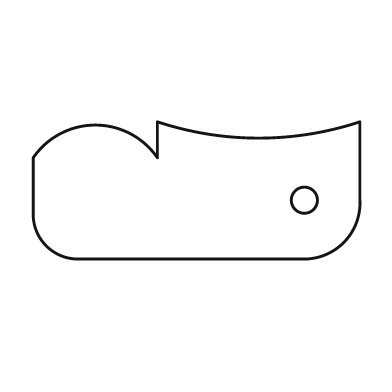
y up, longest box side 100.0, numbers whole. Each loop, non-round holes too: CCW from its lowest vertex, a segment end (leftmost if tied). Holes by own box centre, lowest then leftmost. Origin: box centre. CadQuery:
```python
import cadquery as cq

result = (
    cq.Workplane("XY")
    .moveTo(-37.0, -21.0)
    .lineTo(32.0, -21.0)
    .threePointArc((45.0, -16.0), (50.0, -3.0))
    .lineTo(50.0, 21.0)
    .threePointArc((19.0, 16.0), (-12.0, 21.0))
    .lineTo(-12.0, 10.0)
    .threePointArc((-31.0, 20.0), (-50.0, 10.0))
    .lineTo(-50.0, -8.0)
    .threePointArc((-46.0, -17.0), (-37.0, -21.0))
    .close()
    .moveTo(33.0, -3.0)
    .circle(4.0)
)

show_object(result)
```